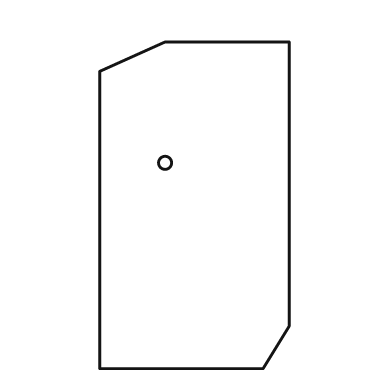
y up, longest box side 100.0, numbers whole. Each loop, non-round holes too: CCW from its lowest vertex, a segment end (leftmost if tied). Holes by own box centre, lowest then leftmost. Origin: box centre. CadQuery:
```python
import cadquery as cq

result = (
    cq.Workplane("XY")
    .moveTo(-29.0, -50.0)
    .lineTo(21.0, -50.0)
    .lineTo(29.0, -37.0)
    .lineTo(29.0, 50.0)
    .lineTo(-9.0, 50.0)
    .lineTo(-29.0, 41.0)
    .close()
    .moveTo(-9.0, 13.0)
    .circle(2.0)
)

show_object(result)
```